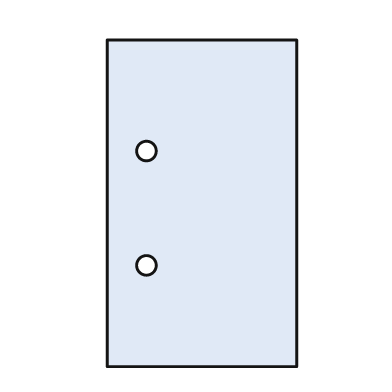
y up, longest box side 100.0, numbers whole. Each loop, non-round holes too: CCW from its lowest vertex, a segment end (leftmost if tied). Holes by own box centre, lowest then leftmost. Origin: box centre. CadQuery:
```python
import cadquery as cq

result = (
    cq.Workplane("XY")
    .moveTo(-29.0, -50.0)
    .lineTo(29.0, -50.0)
    .lineTo(29.0, 50.0)
    .lineTo(-29.0, 50.0)
    .close()
    .moveTo(-17.0, -19.0)
    .circle(3.0)
    .moveTo(-17.0, 16.0)
    .circle(3.0)
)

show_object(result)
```